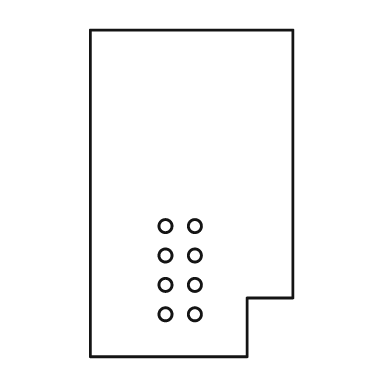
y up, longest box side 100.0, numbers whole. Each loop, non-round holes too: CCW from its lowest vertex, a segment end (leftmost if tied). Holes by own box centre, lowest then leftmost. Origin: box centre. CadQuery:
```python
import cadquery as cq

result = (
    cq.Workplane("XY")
    .moveTo(-31.0, -50.0)
    .lineTo(17.0, -50.0)
    .lineTo(17.0, -32.0)
    .lineTo(31.0, -32.0)
    .lineTo(31.0, 50.0)
    .lineTo(-31.0, 50.0)
    .close()
    .moveTo(-8.0, -37.0)
    .circle(2.0)
    .moveTo(1.0, -37.0)
    .circle(2.0)
    .moveTo(-8.0, -28.0)
    .circle(2.0)
    .moveTo(1.0, -28.0)
    .circle(2.0)
    .moveTo(-8.0, -19.0)
    .circle(2.0)
    .moveTo(1.0, -19.0)
    .circle(2.0)
    .moveTo(-8.0, -10.0)
    .circle(2.0)
    .moveTo(1.0, -10.0)
    .circle(2.0)
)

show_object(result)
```